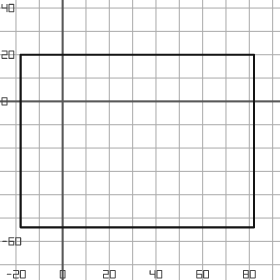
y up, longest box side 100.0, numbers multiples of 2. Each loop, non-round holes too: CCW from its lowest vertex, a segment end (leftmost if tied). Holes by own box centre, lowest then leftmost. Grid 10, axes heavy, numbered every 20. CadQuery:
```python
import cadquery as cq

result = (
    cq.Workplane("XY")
    .moveTo(-18.0, -54.0)
    .lineTo(82.0, -54.0)
    .lineTo(82.0, 20.0)
    .lineTo(-18.0, 20.0)
    .close()
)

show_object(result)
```